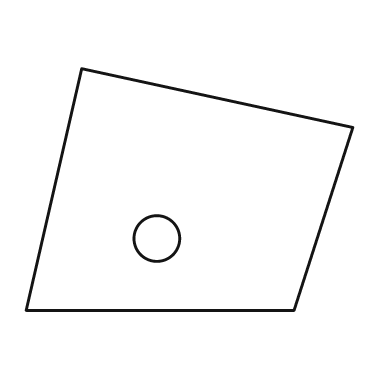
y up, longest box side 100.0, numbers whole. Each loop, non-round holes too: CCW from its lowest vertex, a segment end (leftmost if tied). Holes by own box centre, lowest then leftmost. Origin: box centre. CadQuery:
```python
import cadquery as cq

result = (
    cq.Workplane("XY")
    .moveTo(-50.0, -37.0)
    .lineTo(32.0, -37.0)
    .lineTo(50.0, 19.0)
    .lineTo(-33.0, 37.0)
    .close()
    .moveTo(-10.0, -15.0)
    .circle(7.0)
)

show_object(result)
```